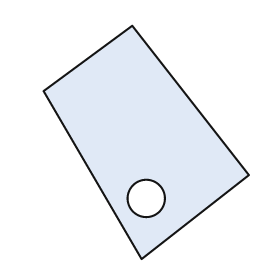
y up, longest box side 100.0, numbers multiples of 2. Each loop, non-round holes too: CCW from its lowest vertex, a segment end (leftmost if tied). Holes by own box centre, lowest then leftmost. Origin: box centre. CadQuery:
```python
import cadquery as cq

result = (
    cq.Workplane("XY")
    .moveTo(-2.0, -50.0)
    .lineTo(44.0, -14.0)
    .lineTo(-6.0, 50.0)
    .lineTo(-44.0, 22.0)
    .close()
    .moveTo(0.0, -24.0)
    .circle(8.0)
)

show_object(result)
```